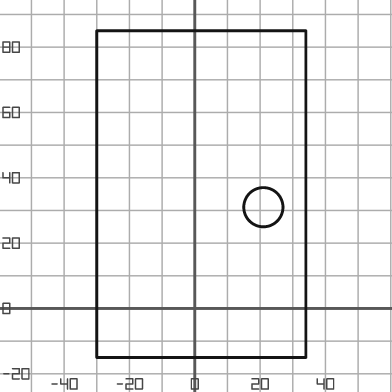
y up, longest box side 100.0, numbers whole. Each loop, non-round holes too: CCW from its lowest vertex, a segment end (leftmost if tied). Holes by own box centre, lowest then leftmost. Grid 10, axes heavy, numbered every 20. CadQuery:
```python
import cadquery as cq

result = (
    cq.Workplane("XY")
    .moveTo(-30.0, -15.0)
    .lineTo(34.0, -15.0)
    .lineTo(34.0, 85.0)
    .lineTo(-30.0, 85.0)
    .close()
    .moveTo(21.0, 31.0)
    .circle(6.0)
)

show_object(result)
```